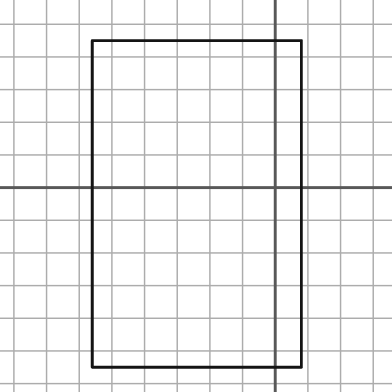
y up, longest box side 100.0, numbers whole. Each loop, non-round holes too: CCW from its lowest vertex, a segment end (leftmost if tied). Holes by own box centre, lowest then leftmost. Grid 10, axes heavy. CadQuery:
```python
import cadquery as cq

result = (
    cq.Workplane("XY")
    .moveTo(-56.0, -55.0)
    .lineTo(8.0, -55.0)
    .lineTo(8.0, 45.0)
    .lineTo(-56.0, 45.0)
    .close()
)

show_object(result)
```